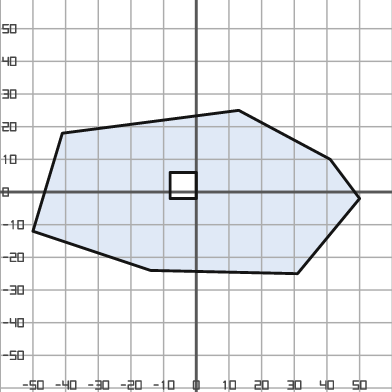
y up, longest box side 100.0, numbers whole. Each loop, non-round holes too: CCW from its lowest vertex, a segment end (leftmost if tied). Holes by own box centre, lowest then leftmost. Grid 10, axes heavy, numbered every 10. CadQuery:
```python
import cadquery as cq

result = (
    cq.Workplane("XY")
    .moveTo(31.0, -25.0)
    .lineTo(50.0, -2.0)
    .lineTo(41.0, 10.0)
    .lineTo(13.0, 25.0)
    .lineTo(-41.0, 18.0)
    .lineTo(-50.0, -12.0)
    .lineTo(-14.0, -24.0)
    .close()
    .moveTo(-8.0, -2.0)
    .lineTo(0.0, -2.0)
    .lineTo(0.0, 6.0)
    .lineTo(-8.0, 6.0)
    .close()
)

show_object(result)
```